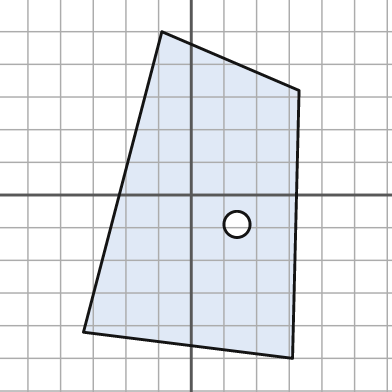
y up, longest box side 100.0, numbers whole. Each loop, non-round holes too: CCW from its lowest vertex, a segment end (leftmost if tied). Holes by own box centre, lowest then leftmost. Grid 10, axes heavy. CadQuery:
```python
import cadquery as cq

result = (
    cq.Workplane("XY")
    .moveTo(31.0, -50.0)
    .lineTo(33.0, 32.0)
    .lineTo(-9.0, 50.0)
    .lineTo(-33.0, -42.0)
    .close()
    .moveTo(14.0, -9.0)
    .circle(4.0)
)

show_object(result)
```